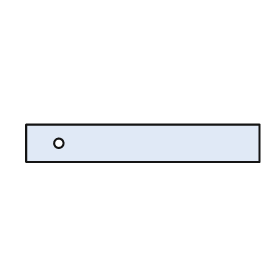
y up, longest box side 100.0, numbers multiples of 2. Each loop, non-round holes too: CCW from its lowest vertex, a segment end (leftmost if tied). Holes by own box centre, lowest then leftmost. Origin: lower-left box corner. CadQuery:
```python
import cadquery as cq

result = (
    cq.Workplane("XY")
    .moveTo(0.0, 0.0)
    .lineTo(100.0, 0.0)
    .lineTo(100.0, 16.0)
    .lineTo(0.0, 16.0)
    .close()
    .moveTo(14.0, 8.0)
    .circle(2.0)
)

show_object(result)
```